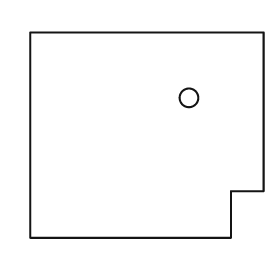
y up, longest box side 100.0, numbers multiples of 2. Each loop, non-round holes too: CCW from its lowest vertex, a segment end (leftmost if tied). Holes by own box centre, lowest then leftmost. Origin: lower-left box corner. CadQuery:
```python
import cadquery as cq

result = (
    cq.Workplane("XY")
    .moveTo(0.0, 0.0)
    .lineTo(86.0, 0.0)
    .lineTo(86.0, 20.0)
    .lineTo(100.0, 20.0)
    .lineTo(100.0, 88.0)
    .lineTo(0.0, 88.0)
    .close()
    .moveTo(68.0, 60.0)
    .circle(4.0)
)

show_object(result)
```